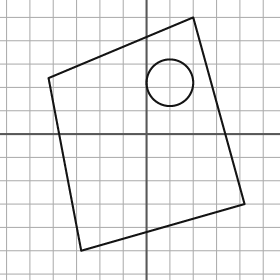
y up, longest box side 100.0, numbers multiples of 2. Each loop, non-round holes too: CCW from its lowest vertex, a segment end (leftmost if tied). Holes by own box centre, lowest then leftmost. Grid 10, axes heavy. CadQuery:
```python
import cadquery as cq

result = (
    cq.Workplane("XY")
    .moveTo(-28.0, -50.0)
    .lineTo(42.0, -30.0)
    .lineTo(20.0, 50.0)
    .lineTo(-42.0, 24.0)
    .close()
    .moveTo(10.0, 22.0)
    .circle(10.0)
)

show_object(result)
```